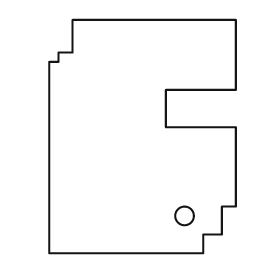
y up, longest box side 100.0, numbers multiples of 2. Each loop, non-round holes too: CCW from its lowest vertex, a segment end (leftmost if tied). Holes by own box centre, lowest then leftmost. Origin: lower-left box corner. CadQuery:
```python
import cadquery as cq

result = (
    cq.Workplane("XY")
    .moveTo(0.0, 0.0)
    .lineTo(66.0, 0.0)
    .lineTo(66.0, 8.0)
    .lineTo(74.0, 8.0)
    .lineTo(74.0, 20.0)
    .lineTo(80.0, 20.0)
    .lineTo(80.0, 54.0)
    .lineTo(50.0, 54.0)
    .lineTo(50.0, 70.0)
    .lineTo(80.0, 70.0)
    .lineTo(80.0, 100.0)
    .lineTo(10.0, 100.0)
    .lineTo(10.0, 86.0)
    .lineTo(4.0, 86.0)
    .lineTo(4.0, 82.0)
    .lineTo(0.0, 82.0)
    .close()
    .moveTo(58.0, 16.0)
    .circle(4.0)
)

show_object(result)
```